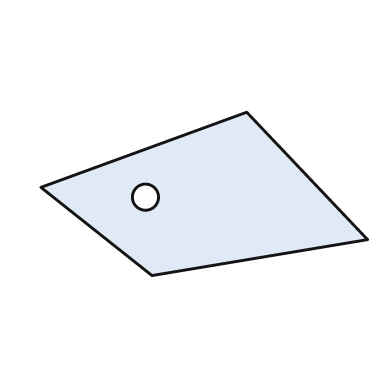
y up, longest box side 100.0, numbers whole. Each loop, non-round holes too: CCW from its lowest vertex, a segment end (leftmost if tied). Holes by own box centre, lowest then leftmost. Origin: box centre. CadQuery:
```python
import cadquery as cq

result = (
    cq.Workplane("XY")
    .moveTo(-16.0, -25.0)
    .lineTo(50.0, -14.0)
    .lineTo(13.0, 25.0)
    .lineTo(-50.0, 2.0)
    .close()
    .moveTo(-18.0, -1.0)
    .circle(4.0)
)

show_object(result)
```